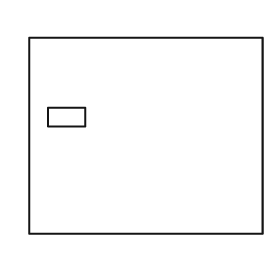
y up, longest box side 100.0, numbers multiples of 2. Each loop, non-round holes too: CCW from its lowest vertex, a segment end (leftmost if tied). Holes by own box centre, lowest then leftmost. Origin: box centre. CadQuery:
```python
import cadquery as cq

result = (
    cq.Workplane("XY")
    .moveTo(-50.0, -42.0)
    .lineTo(50.0, -42.0)
    .lineTo(50.0, 42.0)
    .lineTo(-50.0, 42.0)
    .close()
    .moveTo(-42.0, 4.0)
    .lineTo(-26.0, 4.0)
    .lineTo(-26.0, 12.0)
    .lineTo(-42.0, 12.0)
    .close()
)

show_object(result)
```